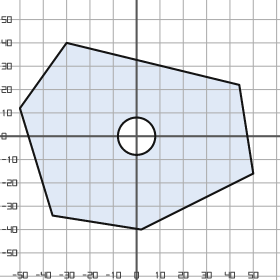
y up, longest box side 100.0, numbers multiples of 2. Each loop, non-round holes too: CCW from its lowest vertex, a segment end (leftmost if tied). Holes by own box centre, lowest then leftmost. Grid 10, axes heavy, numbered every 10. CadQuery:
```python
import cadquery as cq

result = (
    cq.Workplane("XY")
    .moveTo(2.0, -40.0)
    .lineTo(50.0, -16.0)
    .lineTo(44.0, 22.0)
    .lineTo(-30.0, 40.0)
    .lineTo(-50.0, 12.0)
    .lineTo(-36.0, -34.0)
    .close()
    .moveTo(0.0, 0.0)
    .circle(8.0)
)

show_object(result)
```